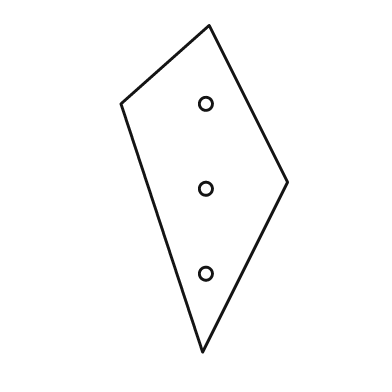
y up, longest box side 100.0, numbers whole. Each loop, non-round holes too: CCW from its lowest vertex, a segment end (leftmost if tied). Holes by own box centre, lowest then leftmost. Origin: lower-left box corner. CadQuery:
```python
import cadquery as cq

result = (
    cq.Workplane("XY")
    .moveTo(25.0, 0.0)
    .lineTo(51.0, 52.0)
    .lineTo(27.0, 100.0)
    .lineTo(0.0, 76.0)
    .close()
    .moveTo(26.0, 24.0)
    .circle(2.0)
    .moveTo(26.0, 50.0)
    .circle(2.0)
    .moveTo(26.0, 76.0)
    .circle(2.0)
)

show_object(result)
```